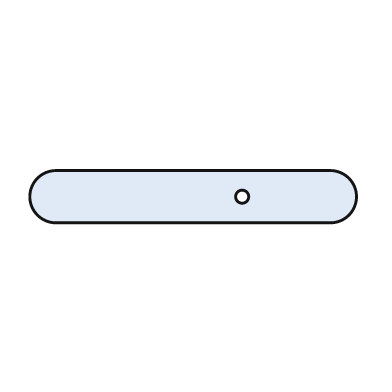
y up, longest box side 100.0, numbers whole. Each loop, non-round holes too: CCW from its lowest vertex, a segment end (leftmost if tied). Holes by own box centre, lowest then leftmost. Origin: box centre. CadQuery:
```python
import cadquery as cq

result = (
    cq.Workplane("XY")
    .moveTo(-42.0, -8.0)
    .lineTo(42.0, -8.0)
    .threePointArc((50.0, 0.0), (42.0, 8.0))
    .lineTo(-42.0, 8.0)
    .threePointArc((-50.0, 0.0), (-42.0, -8.0))
    .close()
    .moveTo(15.0, 0.0)
    .circle(2.0)
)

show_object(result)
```